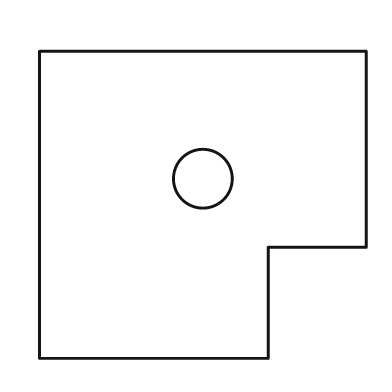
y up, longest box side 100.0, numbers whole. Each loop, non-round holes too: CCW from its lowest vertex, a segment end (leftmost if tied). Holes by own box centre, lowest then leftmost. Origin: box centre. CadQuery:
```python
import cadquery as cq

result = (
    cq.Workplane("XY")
    .moveTo(-50.0, -47.0)
    .lineTo(20.0, -47.0)
    .lineTo(20.0, -13.0)
    .lineTo(50.0, -13.0)
    .lineTo(50.0, 47.0)
    .lineTo(-50.0, 47.0)
    .close()
    .moveTo(0.0, 8.0)
    .circle(9.0)
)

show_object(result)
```